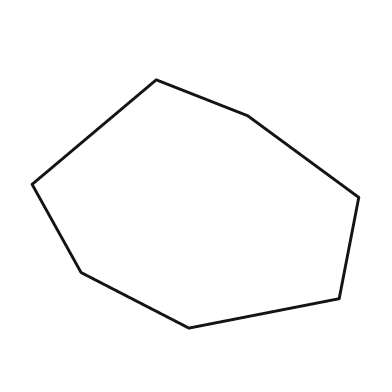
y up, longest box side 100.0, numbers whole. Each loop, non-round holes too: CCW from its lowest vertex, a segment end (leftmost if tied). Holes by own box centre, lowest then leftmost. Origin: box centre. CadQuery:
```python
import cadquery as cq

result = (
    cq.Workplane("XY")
    .moveTo(-2.0, -38.0)
    .lineTo(44.0, -29.0)
    .lineTo(50.0, 2.0)
    .lineTo(16.0, 27.0)
    .lineTo(-12.0, 38.0)
    .lineTo(-50.0, 6.0)
    .lineTo(-35.0, -21.0)
    .close()
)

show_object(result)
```